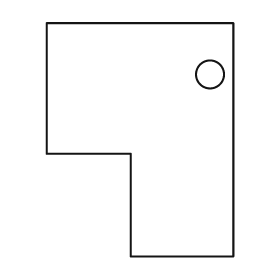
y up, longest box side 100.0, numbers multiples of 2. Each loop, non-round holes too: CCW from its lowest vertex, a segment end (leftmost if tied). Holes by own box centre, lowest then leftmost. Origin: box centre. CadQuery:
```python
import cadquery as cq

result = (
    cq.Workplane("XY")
    .moveTo(-4.0, -50.0)
    .lineTo(40.0, -50.0)
    .lineTo(40.0, 50.0)
    .lineTo(-40.0, 50.0)
    .lineTo(-40.0, -6.0)
    .lineTo(-4.0, -6.0)
    .close()
    .moveTo(30.0, 28.0)
    .circle(6.0)
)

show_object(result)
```